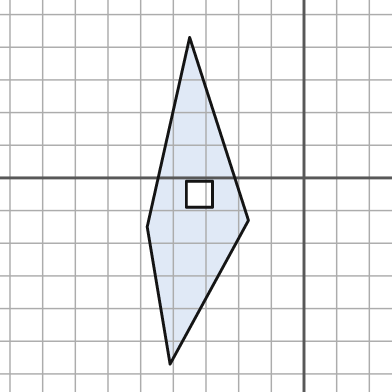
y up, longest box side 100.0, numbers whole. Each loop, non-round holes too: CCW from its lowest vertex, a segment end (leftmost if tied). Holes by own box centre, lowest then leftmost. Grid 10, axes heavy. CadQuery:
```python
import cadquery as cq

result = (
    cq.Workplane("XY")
    .moveTo(-41.0, -57.0)
    .lineTo(-17.0, -13.0)
    .lineTo(-35.0, 43.0)
    .lineTo(-48.0, -15.0)
    .close()
    .moveTo(-36.0, -9.0)
    .lineTo(-28.0, -9.0)
    .lineTo(-28.0, -1.0)
    .lineTo(-36.0, -1.0)
    .close()
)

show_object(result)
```